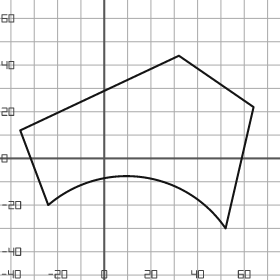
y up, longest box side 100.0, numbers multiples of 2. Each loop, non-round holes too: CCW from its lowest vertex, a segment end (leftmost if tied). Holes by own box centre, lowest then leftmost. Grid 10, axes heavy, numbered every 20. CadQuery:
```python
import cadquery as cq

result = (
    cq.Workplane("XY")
    .moveTo(52.0, -30.0)
    .lineTo(64.0, 22.0)
    .lineTo(32.0, 44.0)
    .lineTo(-36.0, 12.0)
    .lineTo(-24.0, -20.0)
    .threePointArc((16.0, -8.0), (52.0, -30.0))
    .close()
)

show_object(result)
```